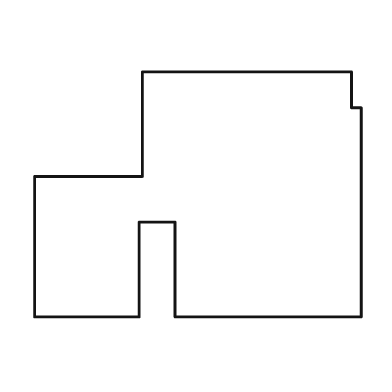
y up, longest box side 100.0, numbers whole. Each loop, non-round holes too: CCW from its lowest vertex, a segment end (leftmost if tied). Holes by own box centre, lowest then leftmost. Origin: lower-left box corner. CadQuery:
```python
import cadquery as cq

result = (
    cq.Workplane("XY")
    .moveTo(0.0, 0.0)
    .lineTo(32.0, 0.0)
    .lineTo(32.0, 29.0)
    .lineTo(43.0, 29.0)
    .lineTo(43.0, 0.0)
    .lineTo(100.0, 0.0)
    .lineTo(100.0, 64.0)
    .lineTo(97.0, 64.0)
    .lineTo(97.0, 75.0)
    .lineTo(33.0, 75.0)
    .lineTo(33.0, 43.0)
    .lineTo(0.0, 43.0)
    .close()
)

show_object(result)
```